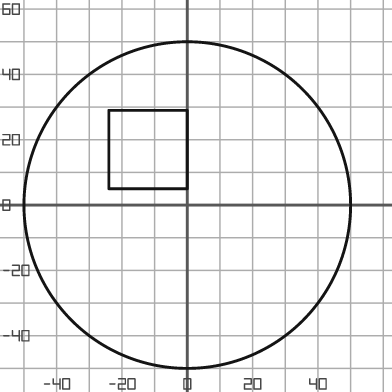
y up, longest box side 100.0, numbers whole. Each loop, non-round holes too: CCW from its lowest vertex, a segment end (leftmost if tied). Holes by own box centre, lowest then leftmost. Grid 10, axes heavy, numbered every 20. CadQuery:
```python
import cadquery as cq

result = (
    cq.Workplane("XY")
    .moveTo(0.0, 0.0)
    .circle(50.0)
    .moveTo(-24.0, 5.0)
    .lineTo(0.0, 5.0)
    .lineTo(0.0, 29.0)
    .lineTo(-24.0, 29.0)
    .close()
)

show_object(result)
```